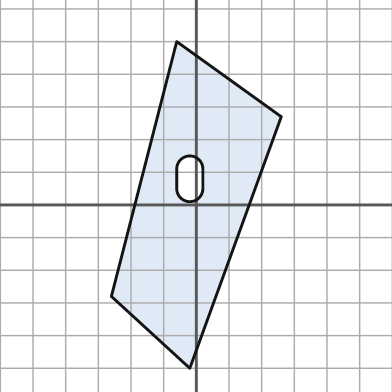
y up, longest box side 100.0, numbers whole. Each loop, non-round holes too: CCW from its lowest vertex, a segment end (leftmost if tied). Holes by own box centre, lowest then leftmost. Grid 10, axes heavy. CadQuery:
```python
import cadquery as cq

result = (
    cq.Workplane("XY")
    .moveTo(-2.0, -50.0)
    .lineTo(26.0, 27.0)
    .lineTo(-6.0, 50.0)
    .lineTo(-26.0, -28.0)
    .close()
    .moveTo(-6.0, 5.0)
    .threePointArc((-2.0, 1.0), (2.0, 5.0))
    .lineTo(2.0, 11.0)
    .threePointArc((-2.0, 15.0), (-6.0, 11.0))
    .close()
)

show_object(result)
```